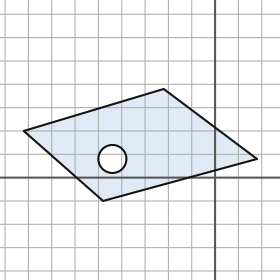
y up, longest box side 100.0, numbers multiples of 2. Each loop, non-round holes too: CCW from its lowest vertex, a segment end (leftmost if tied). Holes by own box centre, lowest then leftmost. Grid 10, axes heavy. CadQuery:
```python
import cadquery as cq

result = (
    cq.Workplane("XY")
    .moveTo(-48.0, -10.0)
    .lineTo(18.0, 8.0)
    .lineTo(-22.0, 38.0)
    .lineTo(-82.0, 20.0)
    .close()
    .moveTo(-44.0, 8.0)
    .circle(6.0)
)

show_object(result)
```